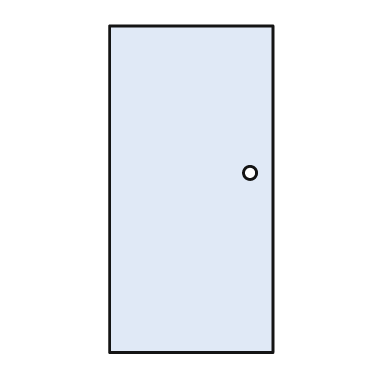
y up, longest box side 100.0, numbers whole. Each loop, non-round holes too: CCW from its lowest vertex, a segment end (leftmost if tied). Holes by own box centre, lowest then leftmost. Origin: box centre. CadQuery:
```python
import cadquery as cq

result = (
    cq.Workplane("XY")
    .moveTo(-25.0, -50.0)
    .lineTo(25.0, -50.0)
    .lineTo(25.0, 50.0)
    .lineTo(-25.0, 50.0)
    .close()
    .moveTo(18.0, 5.0)
    .circle(2.0)
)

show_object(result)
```